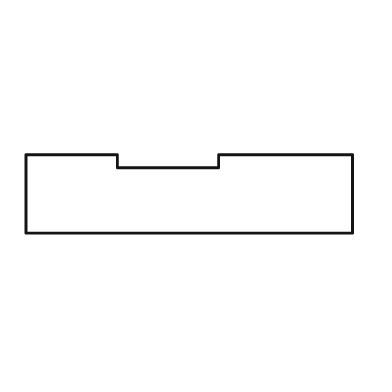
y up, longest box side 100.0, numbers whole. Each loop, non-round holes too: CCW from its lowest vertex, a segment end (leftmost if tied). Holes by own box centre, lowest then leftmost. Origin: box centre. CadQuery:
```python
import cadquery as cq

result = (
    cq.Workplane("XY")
    .moveTo(-50.0, -12.0)
    .lineTo(50.0, -12.0)
    .lineTo(50.0, 12.0)
    .lineTo(9.0, 12.0)
    .lineTo(9.0, 8.0)
    .lineTo(-22.0, 8.0)
    .lineTo(-22.0, 12.0)
    .lineTo(-50.0, 12.0)
    .close()
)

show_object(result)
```